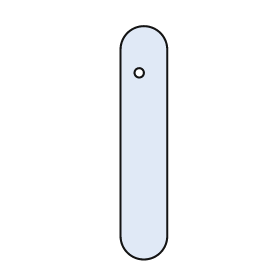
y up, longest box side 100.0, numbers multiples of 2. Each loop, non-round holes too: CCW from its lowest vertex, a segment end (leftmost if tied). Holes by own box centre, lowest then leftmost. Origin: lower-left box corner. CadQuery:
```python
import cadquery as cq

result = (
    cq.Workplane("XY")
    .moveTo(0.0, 10.0)
    .threePointArc((10.0, 0.0), (20.0, 10.0))
    .lineTo(20.0, 90.0)
    .threePointArc((10.0, 100.0), (0.0, 90.0))
    .close()
    .moveTo(8.0, 80.0)
    .circle(2.0)
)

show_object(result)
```